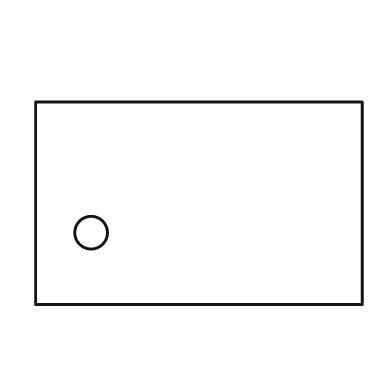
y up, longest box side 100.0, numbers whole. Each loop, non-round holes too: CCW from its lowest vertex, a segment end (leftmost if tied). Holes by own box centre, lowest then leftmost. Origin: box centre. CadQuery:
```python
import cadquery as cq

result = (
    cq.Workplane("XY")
    .moveTo(-50.0, -31.0)
    .lineTo(50.0, -31.0)
    .lineTo(50.0, 31.0)
    .lineTo(-50.0, 31.0)
    .close()
    .moveTo(-33.0, -9.0)
    .circle(5.0)
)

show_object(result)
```